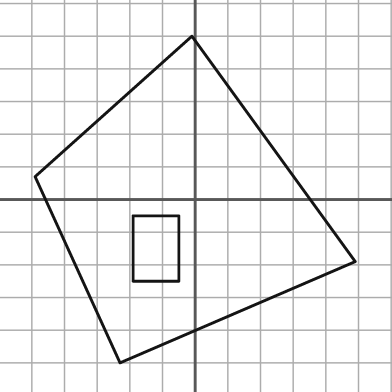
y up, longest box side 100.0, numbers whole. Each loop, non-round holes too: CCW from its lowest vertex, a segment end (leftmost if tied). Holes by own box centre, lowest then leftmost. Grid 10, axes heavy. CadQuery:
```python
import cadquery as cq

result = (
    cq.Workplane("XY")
    .moveTo(-23.0, -50.0)
    .lineTo(49.0, -19.0)
    .lineTo(-1.0, 50.0)
    .lineTo(-49.0, 7.0)
    .close()
    .moveTo(-19.0, -25.0)
    .lineTo(-5.0, -25.0)
    .lineTo(-5.0, -5.0)
    .lineTo(-19.0, -5.0)
    .close()
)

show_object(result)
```